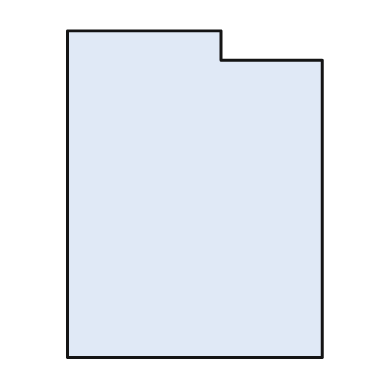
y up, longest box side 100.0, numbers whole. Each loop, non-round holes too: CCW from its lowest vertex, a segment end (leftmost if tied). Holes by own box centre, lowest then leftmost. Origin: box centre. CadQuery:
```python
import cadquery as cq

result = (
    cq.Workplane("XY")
    .moveTo(-39.0, -50.0)
    .lineTo(39.0, -50.0)
    .lineTo(39.0, 41.0)
    .lineTo(8.0, 41.0)
    .lineTo(8.0, 50.0)
    .lineTo(-39.0, 50.0)
    .close()
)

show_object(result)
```